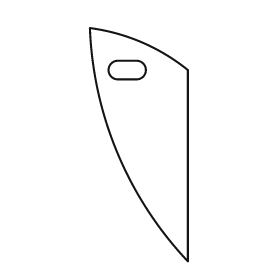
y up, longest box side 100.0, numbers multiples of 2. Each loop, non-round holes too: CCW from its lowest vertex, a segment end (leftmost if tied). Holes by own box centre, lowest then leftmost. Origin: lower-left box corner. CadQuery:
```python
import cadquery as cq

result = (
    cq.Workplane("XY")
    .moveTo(42.0, 0.0)
    .lineTo(42.0, 82.0)
    .threePointArc((22.0, 94.0), (0.0, 100.0))
    .threePointArc((12.0, 46.0), (42.0, 0.0))
    .close()
    .moveTo(12.0, 78.0)
    .lineTo(20.0, 78.0)
    .threePointArc((24.0, 82.0), (20.0, 86.0))
    .lineTo(12.0, 86.0)
    .threePointArc((8.0, 82.0), (12.0, 78.0))
    .close()
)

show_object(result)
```